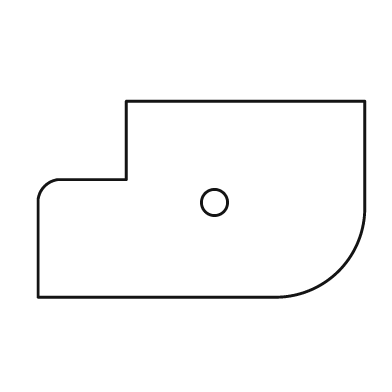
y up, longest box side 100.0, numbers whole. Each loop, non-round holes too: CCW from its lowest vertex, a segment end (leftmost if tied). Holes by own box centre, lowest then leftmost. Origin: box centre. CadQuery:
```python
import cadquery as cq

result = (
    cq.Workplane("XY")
    .moveTo(-50.0, -30.0)
    .lineTo(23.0, -30.0)
    .threePointArc((42.0, -22.0), (50.0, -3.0))
    .lineTo(50.0, 30.0)
    .lineTo(-23.0, 30.0)
    .lineTo(-23.0, 6.0)
    .lineTo(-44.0, 6.0)
    .threePointArc((-48.0, 4.0), (-50.0, 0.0))
    .close()
    .moveTo(4.0, -1.0)
    .circle(4.0)
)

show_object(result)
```